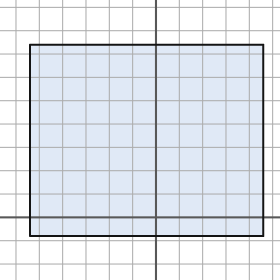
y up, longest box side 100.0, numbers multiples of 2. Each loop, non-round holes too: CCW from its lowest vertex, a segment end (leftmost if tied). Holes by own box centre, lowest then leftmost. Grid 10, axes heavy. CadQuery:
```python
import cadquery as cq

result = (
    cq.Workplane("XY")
    .moveTo(-54.0, -8.0)
    .lineTo(46.0, -8.0)
    .lineTo(46.0, 74.0)
    .lineTo(-54.0, 74.0)
    .close()
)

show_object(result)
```